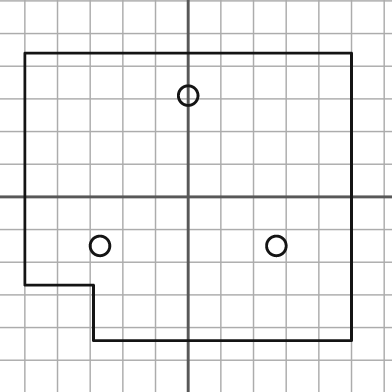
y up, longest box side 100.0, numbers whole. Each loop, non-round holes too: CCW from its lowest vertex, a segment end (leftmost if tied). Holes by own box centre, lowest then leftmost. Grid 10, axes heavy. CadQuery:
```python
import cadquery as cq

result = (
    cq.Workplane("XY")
    .moveTo(-29.0, -44.0)
    .lineTo(50.0, -44.0)
    .lineTo(50.0, 44.0)
    .lineTo(-50.0, 44.0)
    .lineTo(-50.0, -27.0)
    .lineTo(-29.0, -27.0)
    .close()
    .moveTo(-27.0, -15.0)
    .circle(3.0)
    .moveTo(27.0, -15.0)
    .circle(3.0)
    .moveTo(0.0, 31.0)
    .circle(3.0)
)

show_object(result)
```